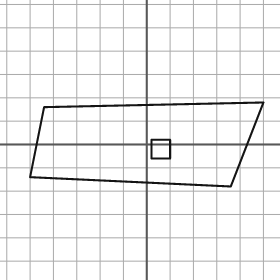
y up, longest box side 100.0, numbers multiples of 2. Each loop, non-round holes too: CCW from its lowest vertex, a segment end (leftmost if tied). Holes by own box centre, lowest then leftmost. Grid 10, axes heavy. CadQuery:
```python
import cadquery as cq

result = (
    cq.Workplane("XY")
    .moveTo(36.0, -18.0)
    .lineTo(50.0, 18.0)
    .lineTo(-44.0, 16.0)
    .lineTo(-50.0, -14.0)
    .close()
    .moveTo(2.0, -6.0)
    .lineTo(10.0, -6.0)
    .lineTo(10.0, 2.0)
    .lineTo(2.0, 2.0)
    .close()
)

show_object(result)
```